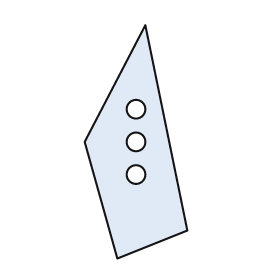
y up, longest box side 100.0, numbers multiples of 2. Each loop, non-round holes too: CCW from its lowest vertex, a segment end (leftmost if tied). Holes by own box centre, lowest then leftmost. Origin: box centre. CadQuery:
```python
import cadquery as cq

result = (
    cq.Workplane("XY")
    .moveTo(-8.0, -50.0)
    .lineTo(22.0, -38.0)
    .lineTo(4.0, 50.0)
    .lineTo(-22.0, 0.0)
    .close()
    .moveTo(0.0, -14.0)
    .circle(4.0)
    .moveTo(0.0, 0.0)
    .circle(4.0)
    .moveTo(0.0, 14.0)
    .circle(4.0)
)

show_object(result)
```